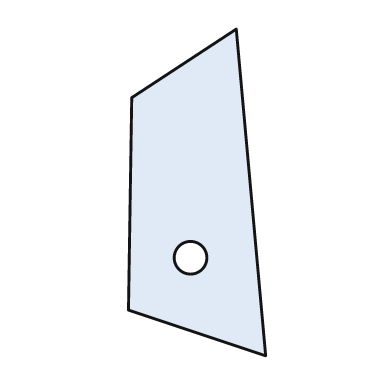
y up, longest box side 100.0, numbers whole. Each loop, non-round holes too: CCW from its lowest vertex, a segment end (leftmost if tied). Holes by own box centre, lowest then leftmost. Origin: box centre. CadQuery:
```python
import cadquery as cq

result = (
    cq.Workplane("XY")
    .moveTo(21.0, -50.0)
    .lineTo(12.0, 50.0)
    .lineTo(-20.0, 29.0)
    .lineTo(-21.0, -36.0)
    .close()
    .moveTo(-2.0, -20.0)
    .circle(5.0)
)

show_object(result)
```